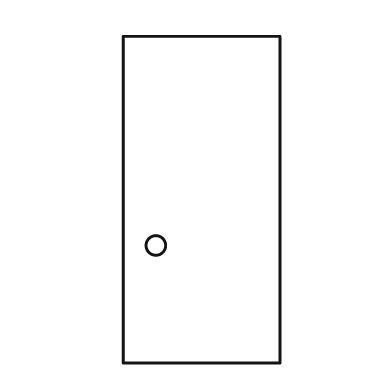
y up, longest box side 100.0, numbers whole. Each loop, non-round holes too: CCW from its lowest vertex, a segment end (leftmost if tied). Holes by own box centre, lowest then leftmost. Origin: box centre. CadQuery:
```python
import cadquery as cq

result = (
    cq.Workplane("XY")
    .moveTo(-24.0, -50.0)
    .lineTo(24.0, -50.0)
    .lineTo(24.0, 50.0)
    .lineTo(-24.0, 50.0)
    .close()
    .moveTo(-14.0, -14.0)
    .circle(3.0)
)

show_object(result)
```